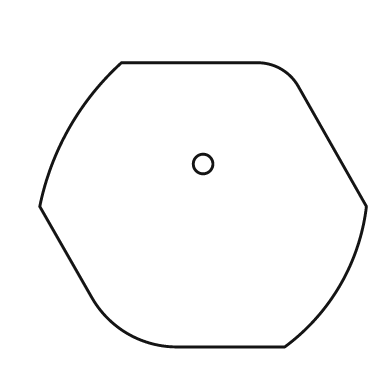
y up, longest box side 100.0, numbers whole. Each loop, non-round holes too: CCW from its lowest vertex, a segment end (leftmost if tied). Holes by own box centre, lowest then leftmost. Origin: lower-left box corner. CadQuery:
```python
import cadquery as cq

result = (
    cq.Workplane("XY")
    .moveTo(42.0, 0.0)
    .lineTo(75.0, 0.0)
    .threePointArc((92.0, 19.0), (100.0, 43.0))
    .lineTo(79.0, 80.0)
    .threePointArc((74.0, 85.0), (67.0, 87.0))
    .lineTo(25.0, 87.0)
    .threePointArc((9.0, 67.0), (0.0, 43.0))
    .lineTo(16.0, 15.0)
    .threePointArc((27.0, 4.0), (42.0, 0.0))
    .close()
    .moveTo(50.0, 56.0)
    .circle(3.0)
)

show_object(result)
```